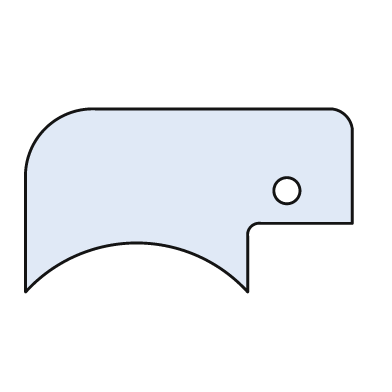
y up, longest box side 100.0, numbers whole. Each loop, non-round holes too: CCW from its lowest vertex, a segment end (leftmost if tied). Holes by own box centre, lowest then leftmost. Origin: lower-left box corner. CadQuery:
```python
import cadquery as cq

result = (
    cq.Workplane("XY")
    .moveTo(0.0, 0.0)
    .threePointArc((34.0, 15.0), (68.0, 0.0))
    .lineTo(68.0, 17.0)
    .threePointArc((69.0, 20.0), (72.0, 21.0))
    .lineTo(100.0, 21.0)
    .lineTo(100.0, 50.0)
    .threePointArc((98.0, 54.0), (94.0, 56.0))
    .lineTo(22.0, 56.0)
    .threePointArc((6.0, 50.0), (0.0, 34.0))
    .close()
    .moveTo(80.0, 31.0)
    .circle(4.0)
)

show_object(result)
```